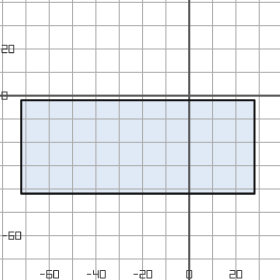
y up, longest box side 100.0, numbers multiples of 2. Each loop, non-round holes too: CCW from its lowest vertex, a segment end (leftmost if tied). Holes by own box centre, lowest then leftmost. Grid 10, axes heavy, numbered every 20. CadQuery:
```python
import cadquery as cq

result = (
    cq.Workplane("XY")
    .moveTo(-72.0, -42.0)
    .lineTo(28.0, -42.0)
    .lineTo(28.0, -2.0)
    .lineTo(-72.0, -2.0)
    .close()
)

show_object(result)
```